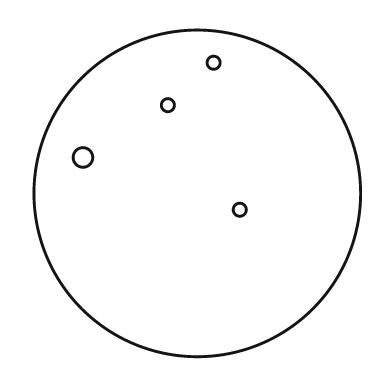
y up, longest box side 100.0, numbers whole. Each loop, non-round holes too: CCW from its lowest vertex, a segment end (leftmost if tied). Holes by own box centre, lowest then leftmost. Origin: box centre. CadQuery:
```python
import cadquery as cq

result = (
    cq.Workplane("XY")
    .moveTo(0.0, 0.0)
    .circle(50.0)
    .moveTo(13.0, -5.0)
    .circle(2.0)
    .moveTo(-35.0, 11.0)
    .circle(3.0)
    .moveTo(-9.0, 27.0)
    .circle(2.0)
    .moveTo(5.0, 40.0)
    .circle(2.0)
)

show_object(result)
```